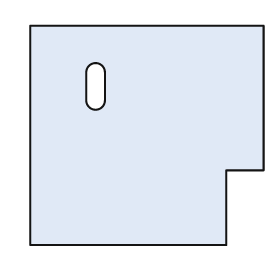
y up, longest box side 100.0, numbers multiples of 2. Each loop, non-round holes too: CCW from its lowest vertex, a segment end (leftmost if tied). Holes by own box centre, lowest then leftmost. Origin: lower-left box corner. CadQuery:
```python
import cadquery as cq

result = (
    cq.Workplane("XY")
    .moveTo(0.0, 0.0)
    .lineTo(84.0, 0.0)
    .lineTo(84.0, 32.0)
    .lineTo(100.0, 32.0)
    .lineTo(100.0, 94.0)
    .lineTo(0.0, 94.0)
    .close()
    .moveTo(24.0, 62.0)
    .threePointArc((28.0, 58.0), (32.0, 62.0))
    .lineTo(32.0, 74.0)
    .threePointArc((28.0, 78.0), (24.0, 74.0))
    .close()
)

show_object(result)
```